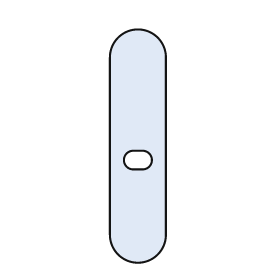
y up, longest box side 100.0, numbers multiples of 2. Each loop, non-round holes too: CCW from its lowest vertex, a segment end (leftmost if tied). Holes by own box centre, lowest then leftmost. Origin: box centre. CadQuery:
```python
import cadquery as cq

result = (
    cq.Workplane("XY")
    .moveTo(-12.0, -38.0)
    .threePointArc((0.0, -50.0), (12.0, -38.0))
    .lineTo(12.0, 38.0)
    .threePointArc((0.0, 50.0), (-12.0, 38.0))
    .close()
    .moveTo(-2.0, -10.0)
    .lineTo(2.0, -10.0)
    .threePointArc((6.0, -6.0), (2.0, -2.0))
    .lineTo(-2.0, -2.0)
    .threePointArc((-6.0, -6.0), (-2.0, -10.0))
    .close()
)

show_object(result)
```